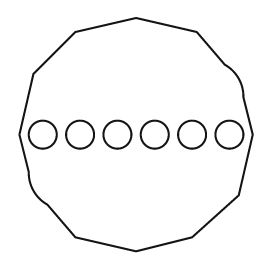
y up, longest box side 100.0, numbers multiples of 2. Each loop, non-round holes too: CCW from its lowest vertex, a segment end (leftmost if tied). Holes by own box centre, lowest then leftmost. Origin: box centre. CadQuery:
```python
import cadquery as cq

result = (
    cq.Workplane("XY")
    .moveTo(0.0, -50.0)
    .lineTo(24.0, -44.0)
    .lineTo(44.0, -26.0)
    .lineTo(50.0, 0.0)
    .lineTo(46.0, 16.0)
    .threePointArc((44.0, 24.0), (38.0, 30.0))
    .lineTo(26.0, 44.0)
    .lineTo(0.0, 50.0)
    .lineTo(-26.0, 44.0)
    .lineTo(-44.0, 26.0)
    .lineTo(-50.0, 0.0)
    .lineTo(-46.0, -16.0)
    .threePointArc((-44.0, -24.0), (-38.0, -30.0))
    .lineTo(-26.0, -44.0)
    .close()
    .moveTo(-40.0, 0.0)
    .circle(6.0)
    .moveTo(-24.0, 0.0)
    .circle(6.0)
    .moveTo(-8.0, 0.0)
    .circle(6.0)
    .moveTo(8.0, 0.0)
    .circle(6.0)
    .moveTo(24.0, 0.0)
    .circle(6.0)
    .moveTo(40.0, 0.0)
    .circle(6.0)
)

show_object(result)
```